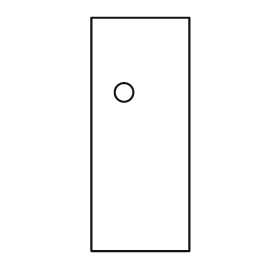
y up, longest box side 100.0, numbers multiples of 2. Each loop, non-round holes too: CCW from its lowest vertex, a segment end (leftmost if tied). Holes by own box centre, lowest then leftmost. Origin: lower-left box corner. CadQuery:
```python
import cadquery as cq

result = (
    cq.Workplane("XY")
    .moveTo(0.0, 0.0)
    .lineTo(42.0, 0.0)
    .lineTo(42.0, 100.0)
    .lineTo(0.0, 100.0)
    .close()
    .moveTo(14.0, 68.0)
    .circle(4.0)
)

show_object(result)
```